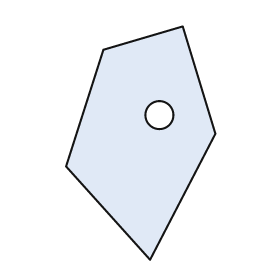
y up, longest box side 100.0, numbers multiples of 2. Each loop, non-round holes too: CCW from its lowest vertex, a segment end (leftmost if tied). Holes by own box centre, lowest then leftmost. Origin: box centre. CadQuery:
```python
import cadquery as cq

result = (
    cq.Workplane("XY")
    .moveTo(4.0, -50.0)
    .lineTo(32.0, 4.0)
    .lineTo(18.0, 50.0)
    .lineTo(-16.0, 40.0)
    .lineTo(-32.0, -10.0)
    .close()
    .moveTo(8.0, 12.0)
    .circle(6.0)
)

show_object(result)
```